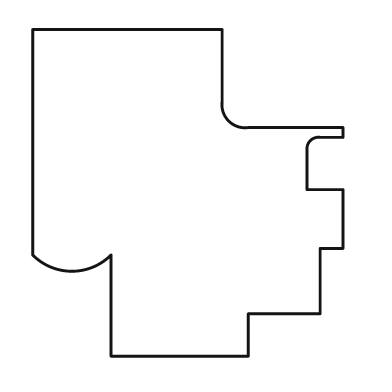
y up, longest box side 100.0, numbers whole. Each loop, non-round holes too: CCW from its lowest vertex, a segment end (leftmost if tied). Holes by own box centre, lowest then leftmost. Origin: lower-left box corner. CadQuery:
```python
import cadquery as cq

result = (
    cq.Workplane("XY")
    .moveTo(24.0, 0.0)
    .lineTo(66.0, 0.0)
    .lineTo(66.0, 13.0)
    .lineTo(88.0, 13.0)
    .lineTo(88.0, 33.0)
    .lineTo(95.0, 33.0)
    .lineTo(95.0, 51.0)
    .lineTo(84.0, 51.0)
    .lineTo(84.0, 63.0)
    .threePointArc((85.0, 66.0), (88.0, 67.0))
    .lineTo(95.0, 67.0)
    .lineTo(95.0, 70.0)
    .lineTo(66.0, 70.0)
    .threePointArc((60.0, 72.0), (58.0, 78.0))
    .lineTo(58.0, 100.0)
    .lineTo(0.0, 100.0)
    .lineTo(0.0, 31.0)
    .threePointArc((12.0, 26.0), (24.0, 31.0))
    .close()
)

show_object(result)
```